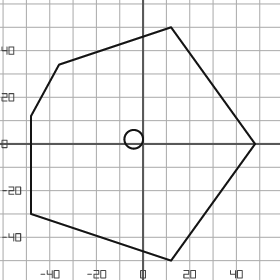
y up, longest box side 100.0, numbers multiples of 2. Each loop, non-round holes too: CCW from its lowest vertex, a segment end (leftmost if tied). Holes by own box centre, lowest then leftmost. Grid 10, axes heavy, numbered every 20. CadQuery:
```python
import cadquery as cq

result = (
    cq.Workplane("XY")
    .moveTo(12.0, -50.0)
    .lineTo(48.0, 0.0)
    .lineTo(12.0, 50.0)
    .lineTo(-36.0, 34.0)
    .lineTo(-48.0, 12.0)
    .lineTo(-48.0, -30.0)
    .close()
    .moveTo(-4.0, 2.0)
    .circle(4.0)
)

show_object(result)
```